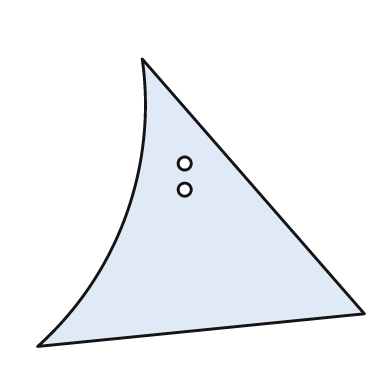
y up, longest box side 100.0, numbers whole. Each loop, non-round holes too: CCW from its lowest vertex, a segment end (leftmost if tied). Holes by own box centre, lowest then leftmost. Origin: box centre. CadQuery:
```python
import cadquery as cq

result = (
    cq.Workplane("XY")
    .moveTo(-50.0, -44.0)
    .lineTo(50.0, -34.0)
    .lineTo(-18.0, 44.0)
    .threePointArc((-23.0, -4.0), (-50.0, -44.0))
    .close()
    .moveTo(-5.0, 4.0)
    .circle(2.0)
    .moveTo(-5.0, 12.0)
    .circle(2.0)
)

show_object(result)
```